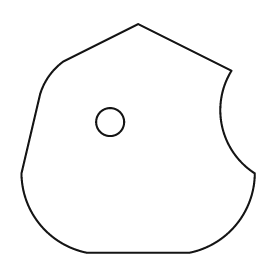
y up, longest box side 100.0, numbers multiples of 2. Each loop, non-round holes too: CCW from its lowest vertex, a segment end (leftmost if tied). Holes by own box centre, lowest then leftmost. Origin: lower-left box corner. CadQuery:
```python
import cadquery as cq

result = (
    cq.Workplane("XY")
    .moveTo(28.0, 0.0)
    .lineTo(72.0, 0.0)
    .threePointArc((92.0, 12.0), (100.0, 34.0))
    .threePointArc((86.0, 54.0), (90.0, 78.0))
    .lineTo(50.0, 98.0)
    .lineTo(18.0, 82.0)
    .threePointArc((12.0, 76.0), (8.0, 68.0))
    .lineTo(0.0, 34.0)
    .threePointArc((8.0, 12.0), (28.0, 0.0))
    .close()
    .moveTo(38.0, 56.0)
    .circle(6.0)
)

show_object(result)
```